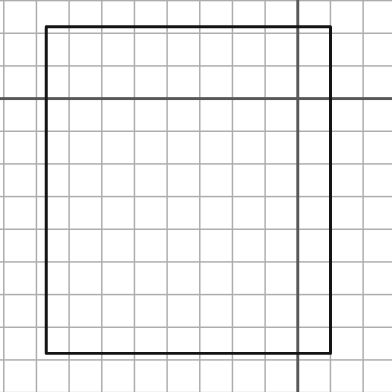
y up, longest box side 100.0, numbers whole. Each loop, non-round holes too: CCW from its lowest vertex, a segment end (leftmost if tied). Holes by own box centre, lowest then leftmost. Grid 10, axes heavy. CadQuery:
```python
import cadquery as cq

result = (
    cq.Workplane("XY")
    .moveTo(-77.0, -78.0)
    .lineTo(10.0, -78.0)
    .lineTo(10.0, 22.0)
    .lineTo(-77.0, 22.0)
    .close()
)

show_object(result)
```